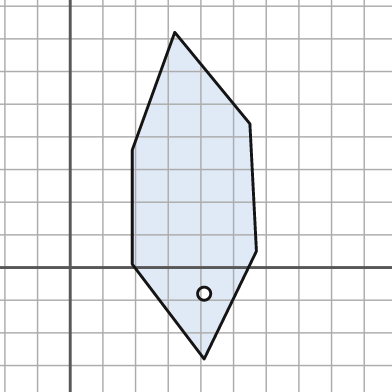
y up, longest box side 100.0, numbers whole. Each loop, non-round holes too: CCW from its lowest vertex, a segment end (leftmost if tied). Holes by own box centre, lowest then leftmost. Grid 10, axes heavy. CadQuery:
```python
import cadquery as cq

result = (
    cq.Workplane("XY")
    .moveTo(41.0, -28.0)
    .lineTo(57.0, 5.0)
    .lineTo(55.0, 44.0)
    .lineTo(32.0, 72.0)
    .lineTo(19.0, 36.0)
    .lineTo(19.0, 1.0)
    .close()
    .moveTo(41.0, -8.0)
    .circle(2.0)
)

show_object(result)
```